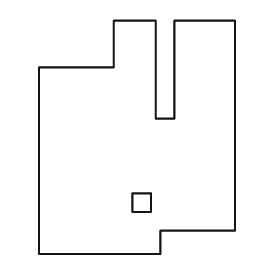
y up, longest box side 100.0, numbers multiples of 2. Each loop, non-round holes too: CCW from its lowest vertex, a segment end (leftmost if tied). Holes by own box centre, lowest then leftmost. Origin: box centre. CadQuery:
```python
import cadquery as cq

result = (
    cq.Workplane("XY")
    .moveTo(-42.0, -50.0)
    .lineTo(10.0, -50.0)
    .lineTo(10.0, -40.0)
    .lineTo(42.0, -40.0)
    .lineTo(42.0, 50.0)
    .lineTo(16.0, 50.0)
    .lineTo(16.0, 8.0)
    .lineTo(8.0, 8.0)
    .lineTo(8.0, 50.0)
    .lineTo(-10.0, 50.0)
    .lineTo(-10.0, 30.0)
    .lineTo(-42.0, 30.0)
    .close()
    .moveTo(-2.0, -32.0)
    .lineTo(6.0, -32.0)
    .lineTo(6.0, -24.0)
    .lineTo(-2.0, -24.0)
    .close()
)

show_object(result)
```